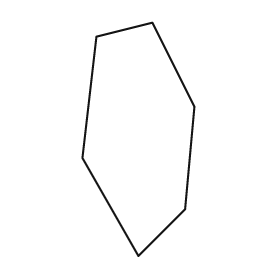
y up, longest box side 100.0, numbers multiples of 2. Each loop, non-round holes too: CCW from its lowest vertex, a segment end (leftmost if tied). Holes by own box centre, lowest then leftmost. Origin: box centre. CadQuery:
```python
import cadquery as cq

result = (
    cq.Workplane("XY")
    .moveTo(0.0, -50.0)
    .lineTo(20.0, -30.0)
    .lineTo(24.0, 14.0)
    .lineTo(6.0, 50.0)
    .lineTo(-18.0, 44.0)
    .lineTo(-24.0, -8.0)
    .close()
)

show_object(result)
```